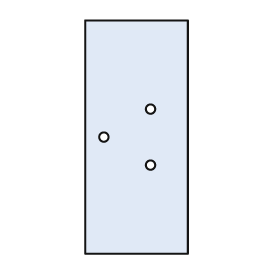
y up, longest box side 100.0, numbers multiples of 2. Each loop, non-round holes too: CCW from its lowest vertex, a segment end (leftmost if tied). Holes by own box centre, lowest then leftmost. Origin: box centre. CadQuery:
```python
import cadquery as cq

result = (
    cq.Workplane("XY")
    .moveTo(-22.0, -50.0)
    .lineTo(22.0, -50.0)
    .lineTo(22.0, 50.0)
    .lineTo(-22.0, 50.0)
    .close()
    .moveTo(6.0, -12.0)
    .circle(2.0)
    .moveTo(-14.0, 0.0)
    .circle(2.0)
    .moveTo(6.0, 12.0)
    .circle(2.0)
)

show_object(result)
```